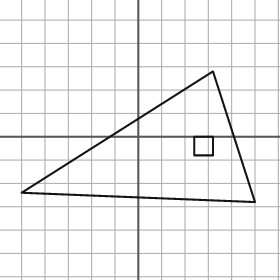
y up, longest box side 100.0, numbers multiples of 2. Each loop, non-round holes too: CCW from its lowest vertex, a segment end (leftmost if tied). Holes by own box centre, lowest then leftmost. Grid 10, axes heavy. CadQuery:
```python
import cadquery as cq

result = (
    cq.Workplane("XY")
    .moveTo(50.0, -28.0)
    .lineTo(32.0, 28.0)
    .lineTo(-50.0, -24.0)
    .close()
    .moveTo(24.0, -8.0)
    .lineTo(32.0, -8.0)
    .lineTo(32.0, 0.0)
    .lineTo(24.0, 0.0)
    .close()
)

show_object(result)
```